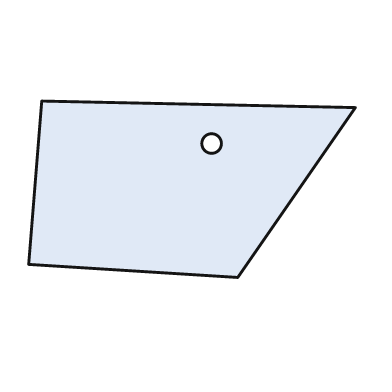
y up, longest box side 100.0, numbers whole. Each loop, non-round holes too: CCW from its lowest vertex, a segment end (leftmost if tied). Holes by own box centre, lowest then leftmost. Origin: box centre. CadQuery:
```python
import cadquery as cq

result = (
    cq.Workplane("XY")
    .moveTo(14.0, -27.0)
    .lineTo(50.0, 25.0)
    .lineTo(-46.0, 27.0)
    .lineTo(-50.0, -23.0)
    .close()
    .moveTo(6.0, 14.0)
    .circle(3.0)
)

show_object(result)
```